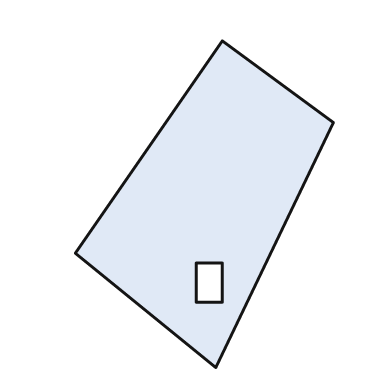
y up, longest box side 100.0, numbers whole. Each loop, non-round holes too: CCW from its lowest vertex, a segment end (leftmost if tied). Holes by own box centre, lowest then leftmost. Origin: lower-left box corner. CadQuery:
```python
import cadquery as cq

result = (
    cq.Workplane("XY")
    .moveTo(43.0, 0.0)
    .lineTo(79.0, 75.0)
    .lineTo(45.0, 100.0)
    .lineTo(0.0, 35.0)
    .close()
    .moveTo(37.0, 20.0)
    .lineTo(45.0, 20.0)
    .lineTo(45.0, 32.0)
    .lineTo(37.0, 32.0)
    .close()
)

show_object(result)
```